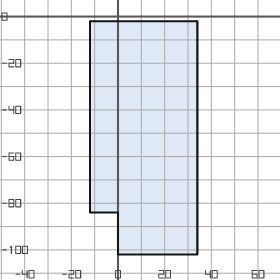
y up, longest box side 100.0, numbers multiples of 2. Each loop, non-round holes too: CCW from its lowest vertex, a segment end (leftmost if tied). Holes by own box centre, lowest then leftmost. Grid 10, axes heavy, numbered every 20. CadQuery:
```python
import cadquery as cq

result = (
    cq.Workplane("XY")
    .moveTo(0.0, -102.0)
    .lineTo(34.0, -102.0)
    .lineTo(34.0, -2.0)
    .lineTo(-12.0, -2.0)
    .lineTo(-12.0, -84.0)
    .lineTo(0.0, -84.0)
    .close()
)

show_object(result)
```